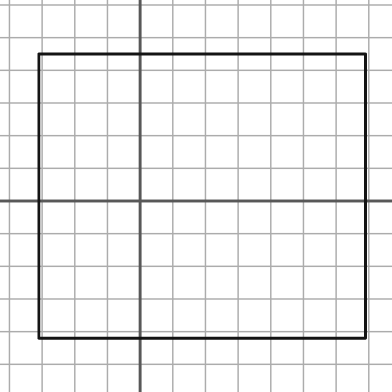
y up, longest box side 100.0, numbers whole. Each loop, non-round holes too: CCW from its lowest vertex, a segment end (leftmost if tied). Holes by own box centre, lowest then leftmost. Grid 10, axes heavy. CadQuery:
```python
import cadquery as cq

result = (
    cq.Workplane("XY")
    .moveTo(-31.0, -42.0)
    .lineTo(69.0, -42.0)
    .lineTo(69.0, 45.0)
    .lineTo(-31.0, 45.0)
    .close()
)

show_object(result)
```